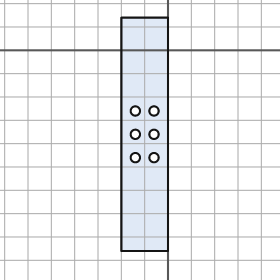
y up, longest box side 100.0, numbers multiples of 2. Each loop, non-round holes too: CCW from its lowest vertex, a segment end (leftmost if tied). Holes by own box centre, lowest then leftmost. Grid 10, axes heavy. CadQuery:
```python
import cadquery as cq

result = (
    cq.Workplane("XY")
    .moveTo(-20.0, -86.0)
    .lineTo(0.0, -86.0)
    .lineTo(0.0, 14.0)
    .lineTo(-20.0, 14.0)
    .close()
    .moveTo(-14.0, -46.0)
    .circle(2.0)
    .moveTo(-6.0, -46.0)
    .circle(2.0)
    .moveTo(-14.0, -36.0)
    .circle(2.0)
    .moveTo(-6.0, -36.0)
    .circle(2.0)
    .moveTo(-14.0, -26.0)
    .circle(2.0)
    .moveTo(-6.0, -26.0)
    .circle(2.0)
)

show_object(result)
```